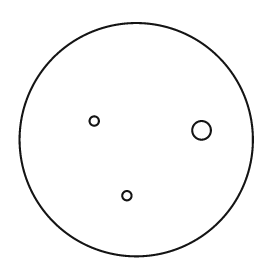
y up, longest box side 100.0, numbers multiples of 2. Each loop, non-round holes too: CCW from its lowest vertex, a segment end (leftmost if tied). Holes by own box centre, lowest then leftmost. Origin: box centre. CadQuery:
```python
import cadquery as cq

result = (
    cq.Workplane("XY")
    .moveTo(0.0, 0.0)
    .circle(50.0)
    .moveTo(-4.0, -24.0)
    .circle(2.0)
    .moveTo(28.0, 4.0)
    .circle(4.0)
    .moveTo(-18.0, 8.0)
    .circle(2.0)
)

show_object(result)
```